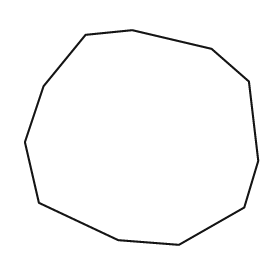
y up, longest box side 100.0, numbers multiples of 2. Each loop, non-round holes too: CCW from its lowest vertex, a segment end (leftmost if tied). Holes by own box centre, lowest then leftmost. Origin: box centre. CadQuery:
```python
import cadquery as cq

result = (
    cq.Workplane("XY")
    .moveTo(16.0, -46.0)
    .lineTo(44.0, -30.0)
    .lineTo(50.0, -10.0)
    .lineTo(46.0, 24.0)
    .lineTo(30.0, 38.0)
    .lineTo(-4.0, 46.0)
    .lineTo(-24.0, 44.0)
    .lineTo(-42.0, 22.0)
    .lineTo(-50.0, -2.0)
    .lineTo(-44.0, -28.0)
    .lineTo(-10.0, -44.0)
    .close()
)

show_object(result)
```